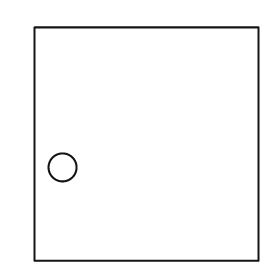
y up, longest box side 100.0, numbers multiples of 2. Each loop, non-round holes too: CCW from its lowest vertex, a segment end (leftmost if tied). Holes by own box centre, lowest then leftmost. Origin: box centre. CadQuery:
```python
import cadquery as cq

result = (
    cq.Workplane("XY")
    .moveTo(-48.0, -50.0)
    .lineTo(48.0, -50.0)
    .lineTo(48.0, 50.0)
    .lineTo(-48.0, 50.0)
    .close()
    .moveTo(-36.0, -10.0)
    .circle(6.0)
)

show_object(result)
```